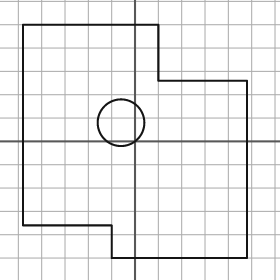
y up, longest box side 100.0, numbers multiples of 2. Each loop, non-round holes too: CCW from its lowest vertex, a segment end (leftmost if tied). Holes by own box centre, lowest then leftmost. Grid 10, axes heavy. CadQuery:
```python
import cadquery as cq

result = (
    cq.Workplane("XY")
    .moveTo(-10.0, -50.0)
    .lineTo(48.0, -50.0)
    .lineTo(48.0, 26.0)
    .lineTo(10.0, 26.0)
    .lineTo(10.0, 50.0)
    .lineTo(-48.0, 50.0)
    .lineTo(-48.0, -36.0)
    .lineTo(-10.0, -36.0)
    .close()
    .moveTo(-6.0, 8.0)
    .circle(10.0)
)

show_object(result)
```